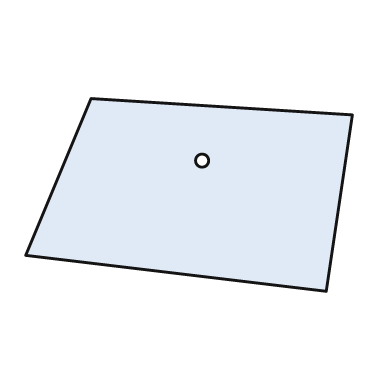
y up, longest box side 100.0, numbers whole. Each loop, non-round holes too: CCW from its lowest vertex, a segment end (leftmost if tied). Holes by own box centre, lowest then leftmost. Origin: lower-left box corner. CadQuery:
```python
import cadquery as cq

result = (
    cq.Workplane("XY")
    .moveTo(92.0, 0.0)
    .lineTo(100.0, 54.0)
    .lineTo(20.0, 59.0)
    .lineTo(0.0, 11.0)
    .close()
    .moveTo(54.0, 40.0)
    .circle(2.0)
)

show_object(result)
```